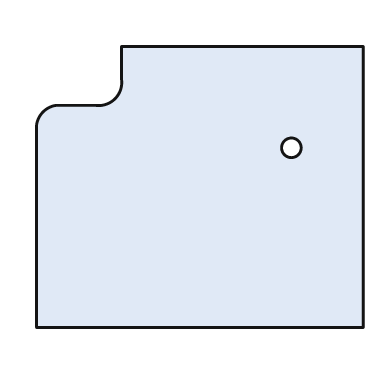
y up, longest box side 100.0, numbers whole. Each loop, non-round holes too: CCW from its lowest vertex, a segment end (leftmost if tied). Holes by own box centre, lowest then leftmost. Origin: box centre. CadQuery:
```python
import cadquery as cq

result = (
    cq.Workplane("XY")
    .moveTo(-50.0, -43.0)
    .lineTo(50.0, -43.0)
    .lineTo(50.0, 43.0)
    .lineTo(-24.0, 43.0)
    .lineTo(-24.0, 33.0)
    .threePointArc((-26.0, 27.0), (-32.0, 25.0))
    .lineTo(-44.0, 25.0)
    .threePointArc((-48.0, 23.0), (-50.0, 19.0))
    .close()
    .moveTo(28.0, 12.0)
    .circle(3.0)
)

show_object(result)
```